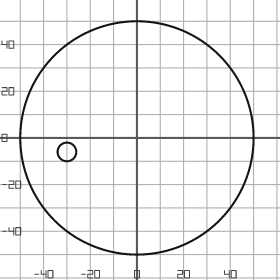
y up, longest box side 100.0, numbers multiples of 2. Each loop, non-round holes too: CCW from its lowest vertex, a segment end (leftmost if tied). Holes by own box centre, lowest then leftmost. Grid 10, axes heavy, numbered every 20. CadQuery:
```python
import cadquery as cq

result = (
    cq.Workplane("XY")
    .moveTo(0.0, 0.0)
    .circle(50.0)
    .moveTo(-30.0, -6.0)
    .circle(4.0)
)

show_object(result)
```